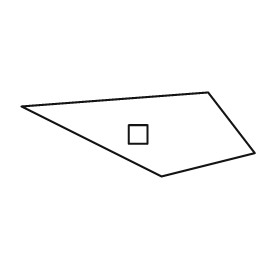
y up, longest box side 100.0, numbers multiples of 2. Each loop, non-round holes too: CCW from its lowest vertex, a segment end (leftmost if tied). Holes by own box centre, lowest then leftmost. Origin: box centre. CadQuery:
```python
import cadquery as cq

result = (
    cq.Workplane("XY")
    .moveTo(10.0, -18.0)
    .lineTo(50.0, -8.0)
    .lineTo(30.0, 18.0)
    .lineTo(-50.0, 12.0)
    .close()
    .moveTo(-4.0, -4.0)
    .lineTo(4.0, -4.0)
    .lineTo(4.0, 4.0)
    .lineTo(-4.0, 4.0)
    .close()
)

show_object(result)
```